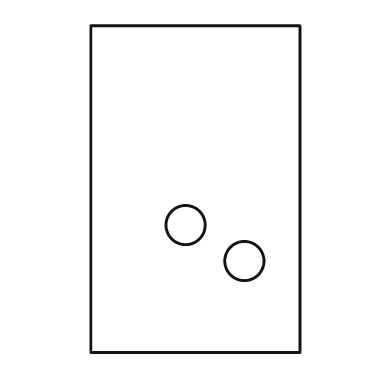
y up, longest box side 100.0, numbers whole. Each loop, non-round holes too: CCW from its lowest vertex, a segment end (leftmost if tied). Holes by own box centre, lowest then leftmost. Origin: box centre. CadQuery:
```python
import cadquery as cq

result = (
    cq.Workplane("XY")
    .moveTo(-32.0, -50.0)
    .lineTo(32.0, -50.0)
    .lineTo(32.0, 50.0)
    .lineTo(-32.0, 50.0)
    .close()
    .moveTo(15.0, -22.0)
    .circle(6.0)
    .moveTo(-3.0, -11.0)
    .circle(6.0)
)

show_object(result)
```